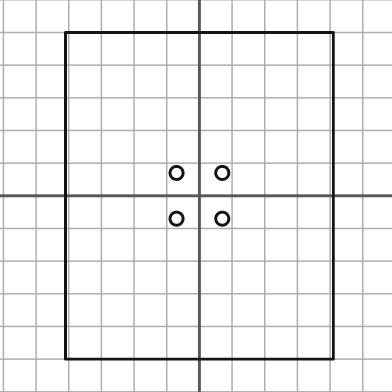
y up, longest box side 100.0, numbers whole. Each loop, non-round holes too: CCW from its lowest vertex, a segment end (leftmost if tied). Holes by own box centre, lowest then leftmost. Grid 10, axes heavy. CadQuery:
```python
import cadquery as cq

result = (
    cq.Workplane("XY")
    .moveTo(-41.0, -50.0)
    .lineTo(41.0, -50.0)
    .lineTo(41.0, 50.0)
    .lineTo(-41.0, 50.0)
    .close()
    .moveTo(-7.0, -7.0)
    .circle(2.0)
    .moveTo(7.0, -7.0)
    .circle(2.0)
    .moveTo(-7.0, 7.0)
    .circle(2.0)
    .moveTo(7.0, 7.0)
    .circle(2.0)
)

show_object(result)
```